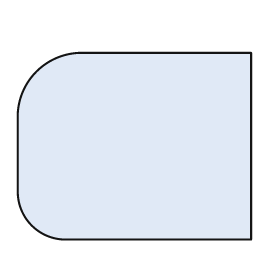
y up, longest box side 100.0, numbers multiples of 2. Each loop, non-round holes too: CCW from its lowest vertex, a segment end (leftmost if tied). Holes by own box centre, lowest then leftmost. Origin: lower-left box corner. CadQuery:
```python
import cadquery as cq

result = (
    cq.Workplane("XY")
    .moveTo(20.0, 0.0)
    .lineTo(100.0, 0.0)
    .lineTo(100.0, 80.0)
    .lineTo(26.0, 80.0)
    .threePointArc((8.0, 72.0), (0.0, 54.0))
    .lineTo(0.0, 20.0)
    .threePointArc((6.0, 6.0), (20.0, 0.0))
    .close()
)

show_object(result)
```